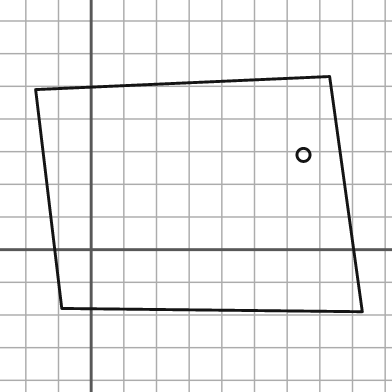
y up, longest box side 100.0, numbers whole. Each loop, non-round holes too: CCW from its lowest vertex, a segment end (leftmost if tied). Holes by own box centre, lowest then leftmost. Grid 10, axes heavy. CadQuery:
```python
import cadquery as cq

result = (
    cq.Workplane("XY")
    .moveTo(83.0, -19.0)
    .lineTo(73.0, 53.0)
    .lineTo(-17.0, 49.0)
    .lineTo(-9.0, -18.0)
    .close()
    .moveTo(65.0, 29.0)
    .circle(2.0)
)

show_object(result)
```